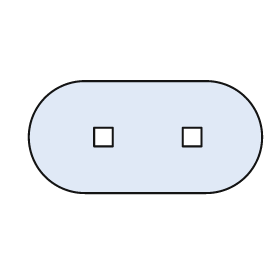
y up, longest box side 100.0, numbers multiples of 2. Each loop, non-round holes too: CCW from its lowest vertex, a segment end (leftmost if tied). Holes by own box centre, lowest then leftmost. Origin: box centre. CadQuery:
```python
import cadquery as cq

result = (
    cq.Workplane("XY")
    .moveTo(-26.0, -24.0)
    .lineTo(26.0, -24.0)
    .threePointArc((50.0, 0.0), (26.0, 24.0))
    .lineTo(-26.0, 24.0)
    .threePointArc((-50.0, 0.0), (-26.0, -24.0))
    .close()
    .moveTo(-22.0, -4.0)
    .lineTo(-14.0, -4.0)
    .lineTo(-14.0, 4.0)
    .lineTo(-22.0, 4.0)
    .close()
    .moveTo(16.0, -4.0)
    .lineTo(24.0, -4.0)
    .lineTo(24.0, 4.0)
    .lineTo(16.0, 4.0)
    .close()
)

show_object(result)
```